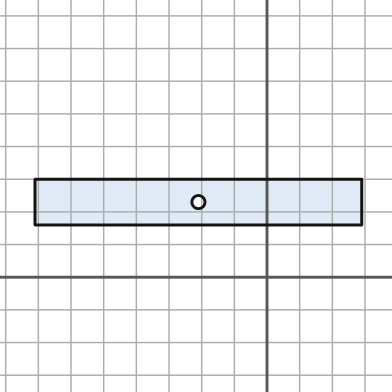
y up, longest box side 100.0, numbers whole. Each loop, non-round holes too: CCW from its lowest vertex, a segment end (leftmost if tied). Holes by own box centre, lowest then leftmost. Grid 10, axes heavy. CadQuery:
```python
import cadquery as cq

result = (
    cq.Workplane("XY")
    .moveTo(-71.0, 16.0)
    .lineTo(29.0, 16.0)
    .lineTo(29.0, 30.0)
    .lineTo(-71.0, 30.0)
    .close()
    .moveTo(-21.0, 23.0)
    .circle(2.0)
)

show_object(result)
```